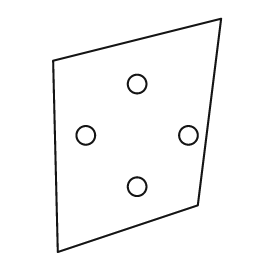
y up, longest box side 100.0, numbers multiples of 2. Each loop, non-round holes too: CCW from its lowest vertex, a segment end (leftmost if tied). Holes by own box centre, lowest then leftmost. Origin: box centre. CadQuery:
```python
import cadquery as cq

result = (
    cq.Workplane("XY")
    .moveTo(-34.0, -50.0)
    .lineTo(26.0, -30.0)
    .lineTo(36.0, 50.0)
    .lineTo(-36.0, 32.0)
    .close()
    .moveTo(0.0, -22.0)
    .circle(4.0)
    .moveTo(-22.0, 0.0)
    .circle(4.0)
    .moveTo(22.0, 0.0)
    .circle(4.0)
    .moveTo(0.0, 22.0)
    .circle(4.0)
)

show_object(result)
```